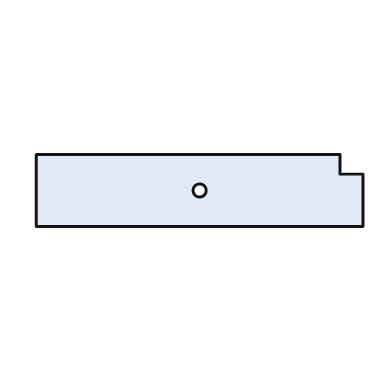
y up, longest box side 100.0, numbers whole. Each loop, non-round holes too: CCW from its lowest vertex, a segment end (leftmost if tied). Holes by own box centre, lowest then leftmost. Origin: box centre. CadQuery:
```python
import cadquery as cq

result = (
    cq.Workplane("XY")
    .moveTo(-50.0, -11.0)
    .lineTo(50.0, -11.0)
    .lineTo(50.0, 5.0)
    .lineTo(43.0, 5.0)
    .lineTo(43.0, 11.0)
    .lineTo(-50.0, 11.0)
    .close()
    .moveTo(0.0, 0.0)
    .circle(2.0)
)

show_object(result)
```